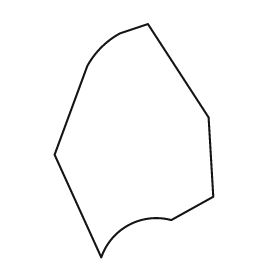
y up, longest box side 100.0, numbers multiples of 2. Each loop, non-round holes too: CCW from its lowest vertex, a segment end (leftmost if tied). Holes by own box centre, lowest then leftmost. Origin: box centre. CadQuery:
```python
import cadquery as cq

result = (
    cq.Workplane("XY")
    .moveTo(-14.0, -50.0)
    .threePointArc((-2.0, -36.0), (16.0, -34.0))
    .lineTo(34.0, -24.0)
    .lineTo(32.0, 10.0)
    .lineTo(6.0, 50.0)
    .lineTo(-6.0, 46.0)
    .threePointArc((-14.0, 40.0), (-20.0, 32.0))
    .lineTo(-34.0, -6.0)
    .close()
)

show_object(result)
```